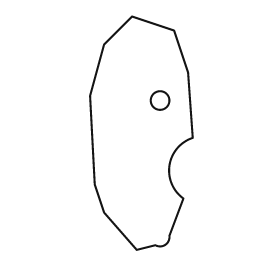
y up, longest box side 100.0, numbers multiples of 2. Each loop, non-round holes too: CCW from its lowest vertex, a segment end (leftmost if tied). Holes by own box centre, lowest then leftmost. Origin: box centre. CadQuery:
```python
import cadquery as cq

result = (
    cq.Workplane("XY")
    .moveTo(-2.0, -50.0)
    .lineTo(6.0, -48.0)
    .threePointArc((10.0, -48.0), (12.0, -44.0))
    .lineTo(18.0, -28.0)
    .threePointArc((12.0, -14.0), (22.0, -2.0))
    .lineTo(20.0, 26.0)
    .lineTo(14.0, 44.0)
    .lineTo(-4.0, 50.0)
    .lineTo(-16.0, 38.0)
    .lineTo(-22.0, 16.0)
    .lineTo(-20.0, -22.0)
    .lineTo(-16.0, -34.0)
    .close()
    .moveTo(8.0, 14.0)
    .circle(4.0)
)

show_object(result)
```